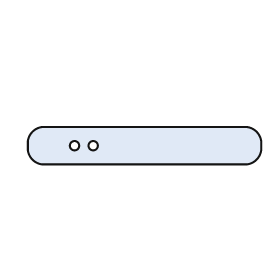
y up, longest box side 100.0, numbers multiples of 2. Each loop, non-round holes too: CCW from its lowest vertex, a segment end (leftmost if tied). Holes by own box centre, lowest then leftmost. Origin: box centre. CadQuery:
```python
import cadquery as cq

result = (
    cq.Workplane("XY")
    .moveTo(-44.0, -8.0)
    .lineTo(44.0, -8.0)
    .threePointArc((48.0, -6.0), (50.0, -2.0))
    .lineTo(50.0, 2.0)
    .threePointArc((48.0, 6.0), (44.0, 8.0))
    .lineTo(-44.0, 8.0)
    .threePointArc((-48.0, 6.0), (-50.0, 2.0))
    .lineTo(-50.0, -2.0)
    .threePointArc((-48.0, -6.0), (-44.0, -8.0))
    .close()
    .moveTo(-30.0, 0.0)
    .circle(2.0)
    .moveTo(-22.0, 0.0)
    .circle(2.0)
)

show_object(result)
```